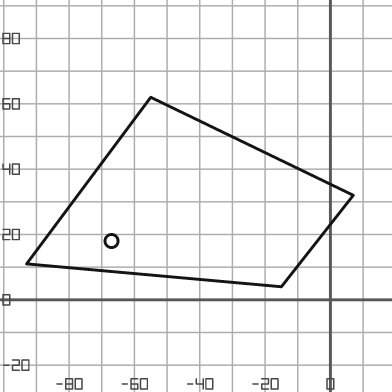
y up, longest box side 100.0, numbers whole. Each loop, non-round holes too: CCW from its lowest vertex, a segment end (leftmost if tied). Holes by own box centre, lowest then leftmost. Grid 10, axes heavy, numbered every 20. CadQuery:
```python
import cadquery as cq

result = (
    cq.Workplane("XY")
    .moveTo(-15.0, 4.0)
    .lineTo(7.0, 32.0)
    .lineTo(-55.0, 62.0)
    .lineTo(-93.0, 11.0)
    .close()
    .moveTo(-67.0, 18.0)
    .circle(2.0)
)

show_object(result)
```